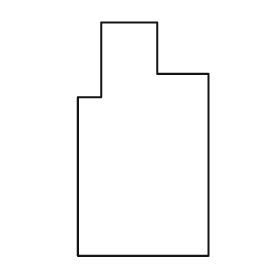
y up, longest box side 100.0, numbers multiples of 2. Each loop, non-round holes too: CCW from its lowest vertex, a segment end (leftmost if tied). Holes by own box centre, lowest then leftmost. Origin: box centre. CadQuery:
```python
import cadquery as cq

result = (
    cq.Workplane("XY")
    .moveTo(-28.0, -50.0)
    .lineTo(28.0, -50.0)
    .lineTo(28.0, 28.0)
    .lineTo(6.0, 28.0)
    .lineTo(6.0, 50.0)
    .lineTo(-18.0, 50.0)
    .lineTo(-18.0, 18.0)
    .lineTo(-28.0, 18.0)
    .close()
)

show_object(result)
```